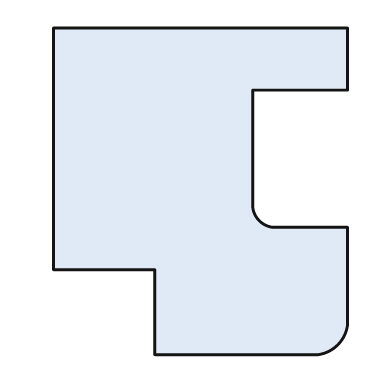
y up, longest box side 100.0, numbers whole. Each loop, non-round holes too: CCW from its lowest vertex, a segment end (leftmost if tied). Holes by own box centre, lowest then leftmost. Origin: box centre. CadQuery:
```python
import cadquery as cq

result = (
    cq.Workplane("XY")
    .moveTo(-14.0, -50.0)
    .lineTo(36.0, -50.0)
    .threePointArc((42.0, -47.0), (45.0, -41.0))
    .lineTo(45.0, -11.0)
    .lineTo(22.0, -11.0)
    .threePointArc((18.0, -9.0), (16.0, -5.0))
    .lineTo(16.0, 31.0)
    .lineTo(45.0, 31.0)
    .lineTo(45.0, 50.0)
    .lineTo(-45.0, 50.0)
    .lineTo(-45.0, -24.0)
    .lineTo(-14.0, -24.0)
    .close()
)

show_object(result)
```